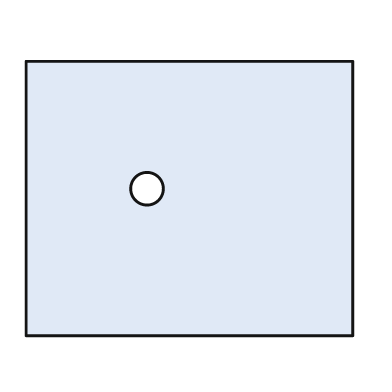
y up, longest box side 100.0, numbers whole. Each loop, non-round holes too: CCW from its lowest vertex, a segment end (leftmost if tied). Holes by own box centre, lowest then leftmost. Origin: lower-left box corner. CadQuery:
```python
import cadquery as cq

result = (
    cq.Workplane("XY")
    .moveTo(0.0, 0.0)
    .lineTo(100.0, 0.0)
    .lineTo(100.0, 84.0)
    .lineTo(0.0, 84.0)
    .close()
    .moveTo(37.0, 45.0)
    .circle(5.0)
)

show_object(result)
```